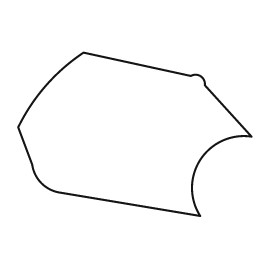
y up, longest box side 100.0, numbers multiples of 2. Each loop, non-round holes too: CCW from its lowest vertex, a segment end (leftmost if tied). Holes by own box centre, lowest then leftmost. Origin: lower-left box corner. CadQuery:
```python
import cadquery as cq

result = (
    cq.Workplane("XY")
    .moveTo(78.0, 0.0)
    .threePointArc((78.0, 24.0), (100.0, 34.0))
    .lineTo(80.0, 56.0)
    .threePointArc((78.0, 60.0), (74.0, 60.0))
    .lineTo(28.0, 70.0)
    .threePointArc((12.0, 56.0), (0.0, 38.0))
    .lineTo(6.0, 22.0)
    .threePointArc((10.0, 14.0), (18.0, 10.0))
    .close()
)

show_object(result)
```